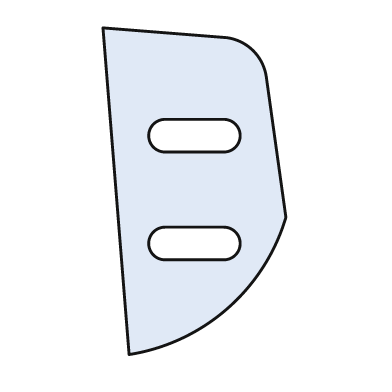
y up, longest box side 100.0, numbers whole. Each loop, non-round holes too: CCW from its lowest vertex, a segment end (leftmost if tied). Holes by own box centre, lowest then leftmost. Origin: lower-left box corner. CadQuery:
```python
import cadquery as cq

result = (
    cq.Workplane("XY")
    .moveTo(8.0, 0.0)
    .threePointArc((38.0, 14.0), (56.0, 42.0))
    .lineTo(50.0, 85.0)
    .threePointArc((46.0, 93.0), (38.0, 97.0))
    .lineTo(0.0, 100.0)
    .close()
    .moveTo(19.0, 29.0)
    .lineTo(37.0, 29.0)
    .threePointArc((42.0, 34.0), (37.0, 39.0))
    .lineTo(19.0, 39.0)
    .threePointArc((14.0, 34.0), (19.0, 29.0))
    .close()
    .moveTo(19.0, 62.0)
    .lineTo(37.0, 62.0)
    .threePointArc((42.0, 67.0), (37.0, 72.0))
    .lineTo(19.0, 72.0)
    .threePointArc((14.0, 67.0), (19.0, 62.0))
    .close()
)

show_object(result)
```